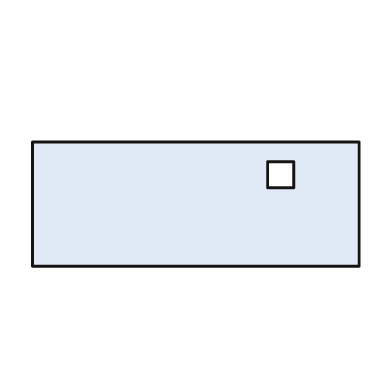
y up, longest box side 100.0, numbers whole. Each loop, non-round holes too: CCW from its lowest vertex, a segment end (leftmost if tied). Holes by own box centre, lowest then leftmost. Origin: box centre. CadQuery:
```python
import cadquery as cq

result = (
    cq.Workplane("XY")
    .moveTo(-50.0, -19.0)
    .lineTo(50.0, -19.0)
    .lineTo(50.0, 19.0)
    .lineTo(-50.0, 19.0)
    .close()
    .moveTo(22.0, 5.0)
    .lineTo(30.0, 5.0)
    .lineTo(30.0, 13.0)
    .lineTo(22.0, 13.0)
    .close()
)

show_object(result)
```